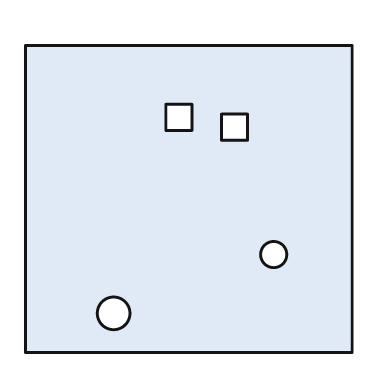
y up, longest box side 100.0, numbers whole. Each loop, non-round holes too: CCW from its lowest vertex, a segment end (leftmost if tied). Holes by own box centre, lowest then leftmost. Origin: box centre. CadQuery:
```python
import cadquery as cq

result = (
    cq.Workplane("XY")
    .moveTo(-50.0, -47.0)
    .lineTo(50.0, -47.0)
    .lineTo(50.0, 47.0)
    .lineTo(-50.0, 47.0)
    .close()
    .moveTo(-23.0, -35.0)
    .circle(5.0)
    .moveTo(26.0, -17.0)
    .circle(4.0)
    .moveTo(10.0, 18.0)
    .lineTo(18.0, 18.0)
    .lineTo(18.0, 26.0)
    .lineTo(10.0, 26.0)
    .close()
    .moveTo(-7.0, 21.0)
    .lineTo(1.0, 21.0)
    .lineTo(1.0, 29.0)
    .lineTo(-7.0, 29.0)
    .close()
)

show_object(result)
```